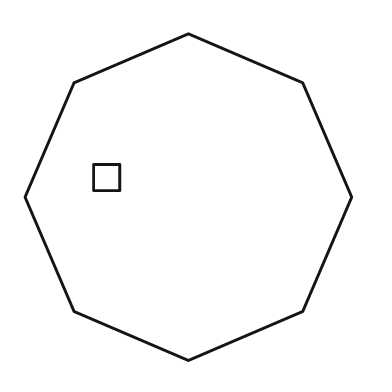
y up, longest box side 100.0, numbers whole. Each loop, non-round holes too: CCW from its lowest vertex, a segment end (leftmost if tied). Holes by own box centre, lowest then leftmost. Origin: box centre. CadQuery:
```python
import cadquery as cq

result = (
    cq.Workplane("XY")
    .moveTo(0.0, -50.0)
    .lineTo(35.0, -35.0)
    .lineTo(50.0, 0.0)
    .lineTo(35.0, 35.0)
    .lineTo(0.0, 50.0)
    .lineTo(-35.0, 35.0)
    .lineTo(-50.0, 0.0)
    .lineTo(-35.0, -35.0)
    .close()
    .moveTo(-29.0, 2.0)
    .lineTo(-21.0, 2.0)
    .lineTo(-21.0, 10.0)
    .lineTo(-29.0, 10.0)
    .close()
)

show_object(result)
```